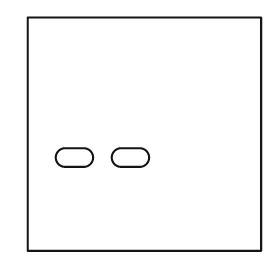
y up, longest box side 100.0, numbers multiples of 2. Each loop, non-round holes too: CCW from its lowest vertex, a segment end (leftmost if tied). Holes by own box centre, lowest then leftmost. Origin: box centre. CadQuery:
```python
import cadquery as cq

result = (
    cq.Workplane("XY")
    .moveTo(-50.0, -50.0)
    .lineTo(50.0, -50.0)
    .lineTo(50.0, 50.0)
    .lineTo(-50.0, 50.0)
    .close()
    .moveTo(-34.0, -14.0)
    .lineTo(-26.0, -14.0)
    .threePointArc((-22.0, -10.0), (-26.0, -6.0))
    .lineTo(-34.0, -6.0)
    .threePointArc((-38.0, -10.0), (-34.0, -14.0))
    .close()
    .moveTo(-10.0, -14.0)
    .lineTo(-2.0, -14.0)
    .threePointArc((2.0, -10.0), (-2.0, -6.0))
    .lineTo(-10.0, -6.0)
    .threePointArc((-14.0, -10.0), (-10.0, -14.0))
    .close()
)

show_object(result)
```